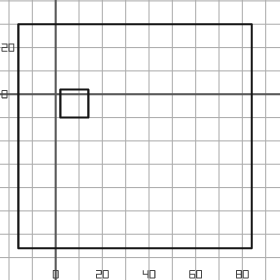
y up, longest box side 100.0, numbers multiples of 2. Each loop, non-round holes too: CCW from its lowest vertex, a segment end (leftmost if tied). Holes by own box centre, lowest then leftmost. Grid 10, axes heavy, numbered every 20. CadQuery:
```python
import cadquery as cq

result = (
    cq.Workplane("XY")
    .moveTo(-16.0, -66.0)
    .lineTo(84.0, -66.0)
    .lineTo(84.0, 30.0)
    .lineTo(-16.0, 30.0)
    .close()
    .moveTo(2.0, -10.0)
    .lineTo(14.0, -10.0)
    .lineTo(14.0, 2.0)
    .lineTo(2.0, 2.0)
    .close()
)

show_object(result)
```